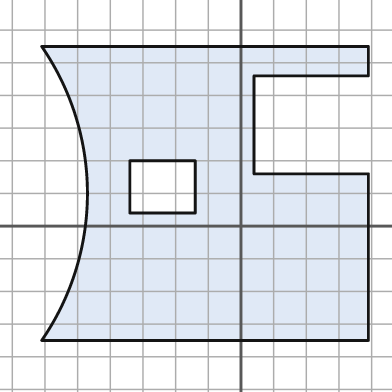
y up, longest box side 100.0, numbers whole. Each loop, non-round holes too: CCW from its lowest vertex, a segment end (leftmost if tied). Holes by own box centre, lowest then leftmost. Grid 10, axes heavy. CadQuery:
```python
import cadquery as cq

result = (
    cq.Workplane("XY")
    .moveTo(-61.0, -35.0)
    .lineTo(39.0, -35.0)
    .lineTo(39.0, 16.0)
    .lineTo(4.0, 16.0)
    .lineTo(4.0, 46.0)
    .lineTo(39.0, 46.0)
    .lineTo(39.0, 55.0)
    .lineTo(-61.0, 55.0)
    .threePointArc((-47.0, 10.0), (-61.0, -35.0))
    .close()
    .moveTo(-34.0, 4.0)
    .lineTo(-14.0, 4.0)
    .lineTo(-14.0, 20.0)
    .lineTo(-34.0, 20.0)
    .close()
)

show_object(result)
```